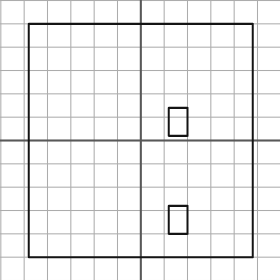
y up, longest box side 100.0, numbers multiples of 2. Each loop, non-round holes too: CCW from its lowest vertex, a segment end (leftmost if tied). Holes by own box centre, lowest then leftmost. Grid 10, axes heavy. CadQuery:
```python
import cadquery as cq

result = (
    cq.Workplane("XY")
    .moveTo(-48.0, -50.0)
    .lineTo(48.0, -50.0)
    .lineTo(48.0, 50.0)
    .lineTo(-48.0, 50.0)
    .close()
    .moveTo(12.0, -40.0)
    .lineTo(20.0, -40.0)
    .lineTo(20.0, -28.0)
    .lineTo(12.0, -28.0)
    .close()
    .moveTo(12.0, 2.0)
    .lineTo(20.0, 2.0)
    .lineTo(20.0, 14.0)
    .lineTo(12.0, 14.0)
    .close()
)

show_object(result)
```